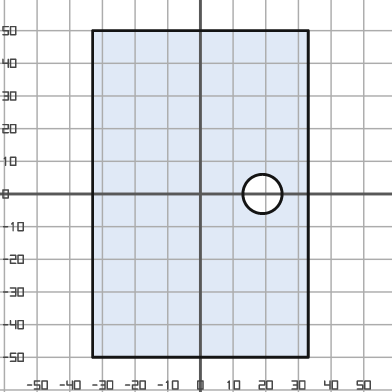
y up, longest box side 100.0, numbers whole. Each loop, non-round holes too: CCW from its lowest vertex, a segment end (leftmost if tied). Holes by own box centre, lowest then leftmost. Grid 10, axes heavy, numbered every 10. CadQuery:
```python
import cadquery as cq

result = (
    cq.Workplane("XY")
    .moveTo(-33.0, -50.0)
    .lineTo(33.0, -50.0)
    .lineTo(33.0, 50.0)
    .lineTo(-33.0, 50.0)
    .close()
    .moveTo(19.0, 0.0)
    .circle(6.0)
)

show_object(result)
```